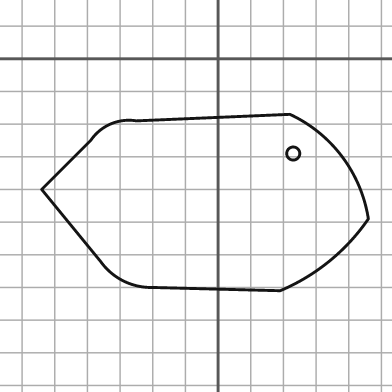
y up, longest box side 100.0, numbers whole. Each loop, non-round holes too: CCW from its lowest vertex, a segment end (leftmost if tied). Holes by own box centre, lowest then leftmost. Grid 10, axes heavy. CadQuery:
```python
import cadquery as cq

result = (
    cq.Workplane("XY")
    .moveTo(19.0, -71.0)
    .threePointArc((34.0, -62.0), (46.0, -49.0))
    .threePointArc((38.0, -30.0), (22.0, -17.0))
    .lineTo(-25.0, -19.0)
    .threePointArc((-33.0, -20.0), (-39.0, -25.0))
    .lineTo(-54.0, -40.0)
    .lineTo(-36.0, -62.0)
    .threePointArc((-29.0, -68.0), (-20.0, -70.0))
    .close()
    .moveTo(23.0, -29.0)
    .circle(2.0)
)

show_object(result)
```